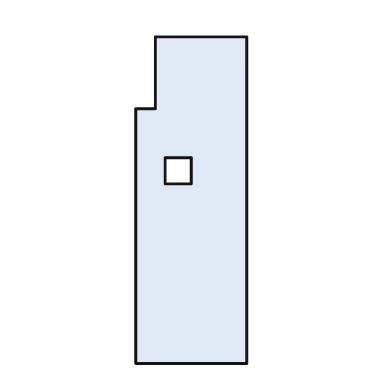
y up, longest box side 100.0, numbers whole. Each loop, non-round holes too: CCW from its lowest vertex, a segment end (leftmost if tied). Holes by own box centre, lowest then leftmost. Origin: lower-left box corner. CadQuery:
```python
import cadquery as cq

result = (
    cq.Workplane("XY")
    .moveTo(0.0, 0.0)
    .lineTo(34.0, 0.0)
    .lineTo(34.0, 100.0)
    .lineTo(6.0, 100.0)
    .lineTo(6.0, 78.0)
    .lineTo(0.0, 78.0)
    .close()
    .moveTo(9.0, 55.0)
    .lineTo(17.0, 55.0)
    .lineTo(17.0, 63.0)
    .lineTo(9.0, 63.0)
    .close()
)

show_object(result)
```